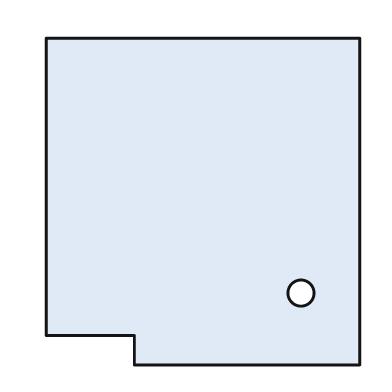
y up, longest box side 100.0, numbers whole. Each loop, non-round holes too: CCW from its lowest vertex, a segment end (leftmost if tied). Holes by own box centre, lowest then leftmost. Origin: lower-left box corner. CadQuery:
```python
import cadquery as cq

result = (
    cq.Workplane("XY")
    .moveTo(27.0, 0.0)
    .lineTo(96.0, 0.0)
    .lineTo(96.0, 100.0)
    .lineTo(0.0, 100.0)
    .lineTo(0.0, 9.0)
    .lineTo(27.0, 9.0)
    .close()
    .moveTo(78.0, 22.0)
    .circle(4.0)
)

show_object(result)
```